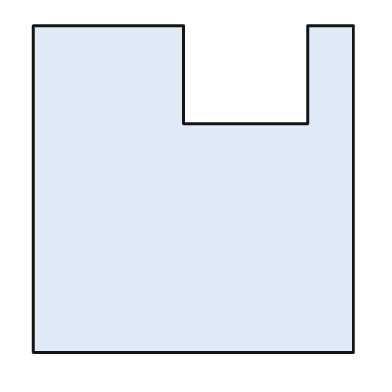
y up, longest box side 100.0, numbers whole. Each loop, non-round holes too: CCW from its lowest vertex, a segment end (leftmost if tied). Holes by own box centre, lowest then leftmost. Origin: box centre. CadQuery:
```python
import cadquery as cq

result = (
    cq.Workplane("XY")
    .moveTo(-49.0, -50.0)
    .lineTo(49.0, -50.0)
    .lineTo(49.0, 50.0)
    .lineTo(35.0, 50.0)
    .lineTo(35.0, 20.0)
    .lineTo(-3.0, 20.0)
    .lineTo(-3.0, 50.0)
    .lineTo(-49.0, 50.0)
    .close()
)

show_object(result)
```